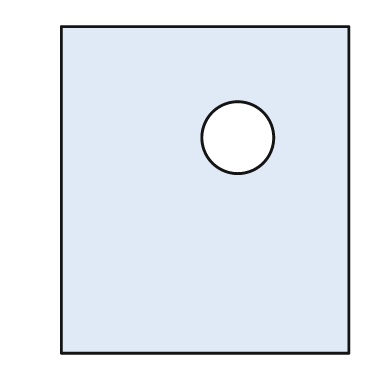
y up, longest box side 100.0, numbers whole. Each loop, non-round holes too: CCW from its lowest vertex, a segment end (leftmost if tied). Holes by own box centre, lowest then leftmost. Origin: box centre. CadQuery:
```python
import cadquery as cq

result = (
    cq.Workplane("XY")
    .moveTo(-44.0, -50.0)
    .lineTo(44.0, -50.0)
    .lineTo(44.0, 50.0)
    .lineTo(-44.0, 50.0)
    .close()
    .moveTo(10.0, 16.0)
    .circle(11.0)
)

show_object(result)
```